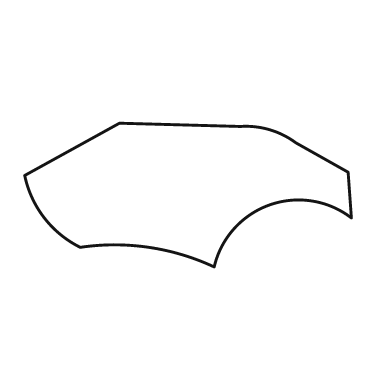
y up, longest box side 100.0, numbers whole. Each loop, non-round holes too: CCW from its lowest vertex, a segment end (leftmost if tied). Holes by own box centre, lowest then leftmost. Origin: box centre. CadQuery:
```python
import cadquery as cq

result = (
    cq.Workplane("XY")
    .moveTo(8.0, -22.0)
    .threePointArc((25.0, -3.0), (50.0, -7.0))
    .lineTo(49.0, 7.0)
    .lineTo(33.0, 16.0)
    .threePointArc((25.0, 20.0), (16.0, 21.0))
    .lineTo(-21.0, 22.0)
    .lineTo(-50.0, 6.0)
    .threePointArc((-44.0, -7.0), (-33.0, -16.0))
    .threePointArc((-12.0, -16.0), (8.0, -22.0))
    .close()
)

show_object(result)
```